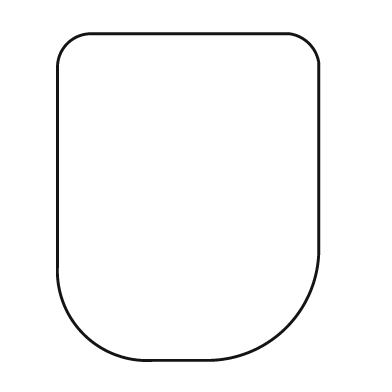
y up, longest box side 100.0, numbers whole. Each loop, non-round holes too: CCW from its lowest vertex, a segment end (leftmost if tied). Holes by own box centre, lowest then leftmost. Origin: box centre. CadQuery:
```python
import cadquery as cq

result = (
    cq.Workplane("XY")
    .moveTo(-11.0, -50.0)
    .lineTo(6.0, -50.0)
    .threePointArc((30.0, -40.0), (40.0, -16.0))
    .lineTo(40.0, 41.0)
    .threePointArc((37.0, 47.0), (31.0, 50.0))
    .lineTo(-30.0, 50.0)
    .threePointArc((-37.0, 47.0), (-40.0, 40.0))
    .lineTo(-40.0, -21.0)
    .threePointArc((-32.0, -42.0), (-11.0, -50.0))
    .close()
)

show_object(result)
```